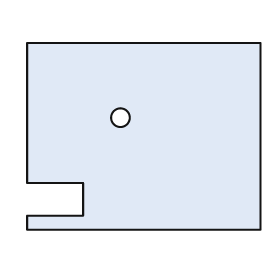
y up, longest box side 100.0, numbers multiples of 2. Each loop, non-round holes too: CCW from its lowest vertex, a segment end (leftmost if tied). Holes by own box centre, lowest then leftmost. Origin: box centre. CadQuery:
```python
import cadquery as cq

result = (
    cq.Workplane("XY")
    .moveTo(-50.0, -40.0)
    .lineTo(50.0, -40.0)
    .lineTo(50.0, 40.0)
    .lineTo(-50.0, 40.0)
    .lineTo(-50.0, -20.0)
    .lineTo(-26.0, -20.0)
    .lineTo(-26.0, -34.0)
    .lineTo(-50.0, -34.0)
    .close()
    .moveTo(-10.0, 8.0)
    .circle(4.0)
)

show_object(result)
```